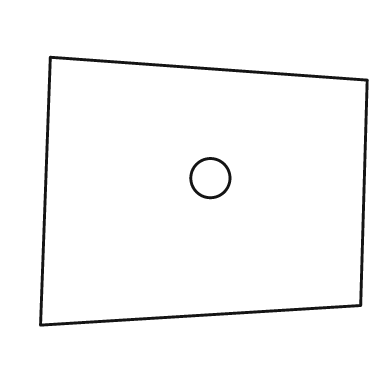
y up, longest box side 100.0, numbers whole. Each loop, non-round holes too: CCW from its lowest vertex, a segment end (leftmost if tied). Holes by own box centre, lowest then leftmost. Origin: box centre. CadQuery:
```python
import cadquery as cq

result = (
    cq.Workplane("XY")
    .moveTo(-50.0, -41.0)
    .lineTo(48.0, -35.0)
    .lineTo(50.0, 34.0)
    .lineTo(-47.0, 41.0)
    .close()
    .moveTo(2.0, 4.0)
    .circle(6.0)
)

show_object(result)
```